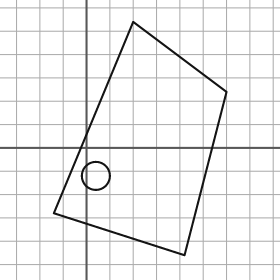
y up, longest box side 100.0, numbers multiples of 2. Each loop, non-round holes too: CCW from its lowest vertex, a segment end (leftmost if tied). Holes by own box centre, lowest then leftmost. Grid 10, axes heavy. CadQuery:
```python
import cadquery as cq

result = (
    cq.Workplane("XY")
    .moveTo(42.0, -46.0)
    .lineTo(60.0, 24.0)
    .lineTo(20.0, 54.0)
    .lineTo(-14.0, -28.0)
    .close()
    .moveTo(4.0, -12.0)
    .circle(6.0)
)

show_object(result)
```